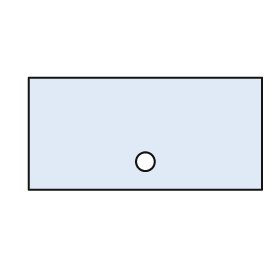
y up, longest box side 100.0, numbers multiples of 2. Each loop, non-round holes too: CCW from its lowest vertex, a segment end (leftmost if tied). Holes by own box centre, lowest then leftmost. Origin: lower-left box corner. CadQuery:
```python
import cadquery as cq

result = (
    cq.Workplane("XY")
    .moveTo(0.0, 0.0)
    .lineTo(100.0, 0.0)
    .lineTo(100.0, 48.0)
    .lineTo(0.0, 48.0)
    .close()
    .moveTo(50.0, 12.0)
    .circle(4.0)
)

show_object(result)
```